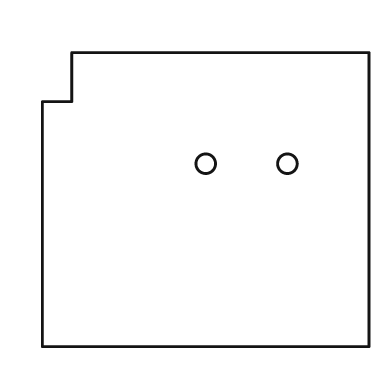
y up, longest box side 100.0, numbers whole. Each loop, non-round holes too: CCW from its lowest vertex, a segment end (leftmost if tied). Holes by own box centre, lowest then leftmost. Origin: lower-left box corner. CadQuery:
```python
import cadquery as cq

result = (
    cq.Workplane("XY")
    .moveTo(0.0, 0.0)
    .lineTo(100.0, 0.0)
    .lineTo(100.0, 90.0)
    .lineTo(9.0, 90.0)
    .lineTo(9.0, 75.0)
    .lineTo(0.0, 75.0)
    .close()
    .moveTo(50.0, 56.0)
    .circle(3.0)
    .moveTo(75.0, 56.0)
    .circle(3.0)
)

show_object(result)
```